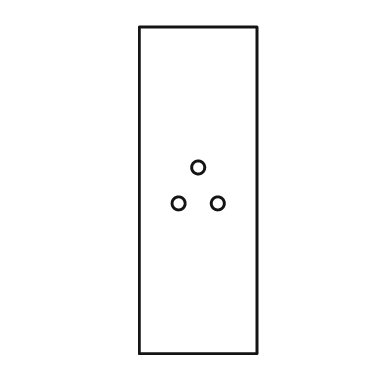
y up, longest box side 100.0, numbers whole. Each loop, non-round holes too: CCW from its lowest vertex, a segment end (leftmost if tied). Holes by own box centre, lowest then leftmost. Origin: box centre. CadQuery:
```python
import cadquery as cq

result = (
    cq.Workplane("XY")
    .moveTo(-18.0, -50.0)
    .lineTo(18.0, -50.0)
    .lineTo(18.0, 50.0)
    .lineTo(-18.0, 50.0)
    .close()
    .moveTo(-6.0, -4.0)
    .circle(2.0)
    .moveTo(6.0, -4.0)
    .circle(2.0)
    .moveTo(0.0, 7.0)
    .circle(2.0)
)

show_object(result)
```